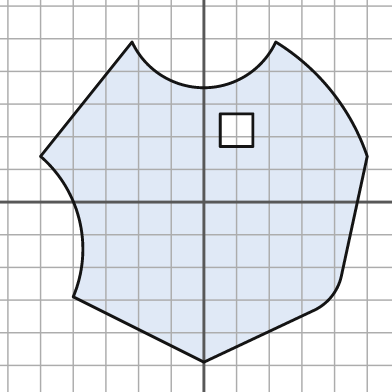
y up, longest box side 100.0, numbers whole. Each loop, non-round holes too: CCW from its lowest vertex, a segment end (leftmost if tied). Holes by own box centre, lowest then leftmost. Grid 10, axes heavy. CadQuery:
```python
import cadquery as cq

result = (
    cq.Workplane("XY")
    .moveTo(0.0, -49.0)
    .lineTo(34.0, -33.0)
    .threePointArc((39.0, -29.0), (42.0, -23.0))
    .lineTo(50.0, 14.0)
    .threePointArc((39.0, 34.0), (22.0, 49.0))
    .threePointArc((0.0, 35.0), (-22.0, 49.0))
    .lineTo(-50.0, 14.0)
    .threePointArc((-38.0, -6.0), (-40.0, -29.0))
    .close()
    .moveTo(5.0, 17.0)
    .lineTo(15.0, 17.0)
    .lineTo(15.0, 27.0)
    .lineTo(5.0, 27.0)
    .close()
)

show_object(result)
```